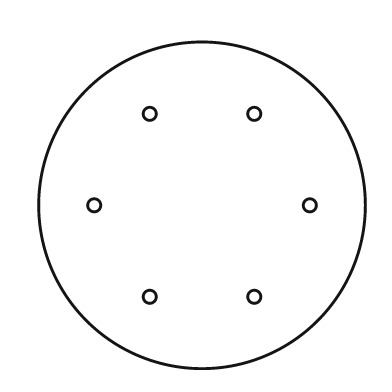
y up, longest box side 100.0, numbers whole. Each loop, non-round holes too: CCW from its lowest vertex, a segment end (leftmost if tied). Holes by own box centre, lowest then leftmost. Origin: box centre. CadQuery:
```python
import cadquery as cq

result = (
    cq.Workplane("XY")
    .moveTo(0.0, 0.0)
    .circle(50.0)
    .moveTo(-16.0, -28.0)
    .circle(2.0)
    .moveTo(16.0, -28.0)
    .circle(2.0)
    .moveTo(-33.0, 0.0)
    .circle(2.0)
    .moveTo(33.0, 0.0)
    .circle(2.0)
    .moveTo(-16.0, 28.0)
    .circle(2.0)
    .moveTo(16.0, 28.0)
    .circle(2.0)
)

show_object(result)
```